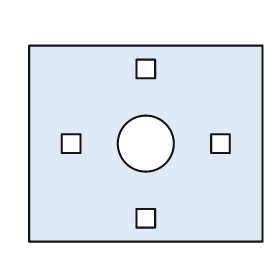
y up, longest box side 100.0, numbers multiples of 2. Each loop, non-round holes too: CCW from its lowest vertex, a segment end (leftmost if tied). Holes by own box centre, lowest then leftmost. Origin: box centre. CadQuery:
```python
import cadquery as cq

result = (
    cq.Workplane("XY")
    .moveTo(-50.0, -42.0)
    .lineTo(50.0, -42.0)
    .lineTo(50.0, 42.0)
    .lineTo(-50.0, 42.0)
    .close()
    .moveTo(-4.0, -36.0)
    .lineTo(4.0, -36.0)
    .lineTo(4.0, -28.0)
    .lineTo(-4.0, -28.0)
    .close()
    .moveTo(-36.0, -4.0)
    .lineTo(-28.0, -4.0)
    .lineTo(-28.0, 4.0)
    .lineTo(-36.0, 4.0)
    .close()
    .moveTo(0.0, 0.0)
    .circle(12.0)
    .moveTo(28.0, -4.0)
    .lineTo(36.0, -4.0)
    .lineTo(36.0, 4.0)
    .lineTo(28.0, 4.0)
    .close()
    .moveTo(-4.0, 28.0)
    .lineTo(4.0, 28.0)
    .lineTo(4.0, 36.0)
    .lineTo(-4.0, 36.0)
    .close()
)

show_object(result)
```